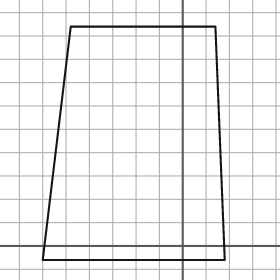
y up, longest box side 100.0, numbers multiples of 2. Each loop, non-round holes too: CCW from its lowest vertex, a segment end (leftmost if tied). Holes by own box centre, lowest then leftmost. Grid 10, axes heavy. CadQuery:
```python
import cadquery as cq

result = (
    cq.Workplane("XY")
    .moveTo(-60.0, -6.0)
    .lineTo(18.0, -6.0)
    .lineTo(14.0, 94.0)
    .lineTo(-48.0, 94.0)
    .close()
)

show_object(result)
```